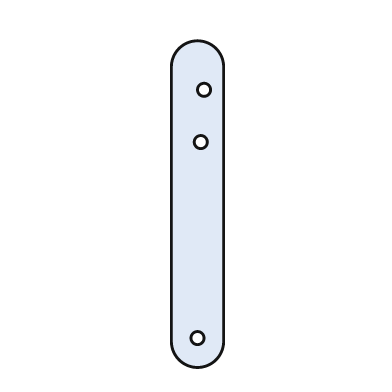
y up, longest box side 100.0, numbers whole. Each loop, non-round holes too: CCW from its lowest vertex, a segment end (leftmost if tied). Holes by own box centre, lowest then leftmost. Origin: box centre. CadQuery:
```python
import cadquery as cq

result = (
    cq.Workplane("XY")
    .moveTo(-8.0, -42.0)
    .threePointArc((0.0, -50.0), (8.0, -42.0))
    .lineTo(8.0, 42.0)
    .threePointArc((0.0, 50.0), (-8.0, 42.0))
    .close()
    .moveTo(0.0, -41.0)
    .circle(2.0)
    .moveTo(1.0, 19.0)
    .circle(2.0)
    .moveTo(2.0, 35.0)
    .circle(2.0)
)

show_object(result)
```